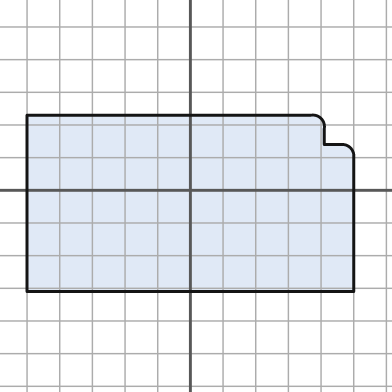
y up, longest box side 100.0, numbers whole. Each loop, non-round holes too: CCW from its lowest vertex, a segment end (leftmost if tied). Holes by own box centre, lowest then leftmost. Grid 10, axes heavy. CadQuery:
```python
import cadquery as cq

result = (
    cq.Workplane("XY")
    .moveTo(-50.0, -31.0)
    .lineTo(50.0, -31.0)
    .lineTo(50.0, 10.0)
    .threePointArc((49.0, 13.0), (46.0, 14.0))
    .lineTo(41.0, 14.0)
    .lineTo(41.0, 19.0)
    .threePointArc((40.0, 22.0), (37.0, 23.0))
    .lineTo(-50.0, 23.0)
    .close()
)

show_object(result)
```